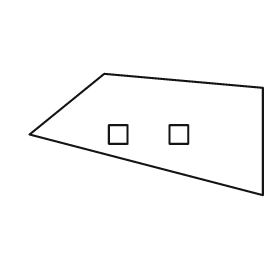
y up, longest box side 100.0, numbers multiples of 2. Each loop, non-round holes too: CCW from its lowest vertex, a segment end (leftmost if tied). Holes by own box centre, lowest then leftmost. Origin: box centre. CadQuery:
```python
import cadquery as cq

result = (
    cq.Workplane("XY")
    .moveTo(50.0, -26.0)
    .lineTo(50.0, 20.0)
    .lineTo(-18.0, 26.0)
    .lineTo(-50.0, 0.0)
    .close()
    .moveTo(-16.0, -4.0)
    .lineTo(-8.0, -4.0)
    .lineTo(-8.0, 4.0)
    .lineTo(-16.0, 4.0)
    .close()
    .moveTo(10.0, -4.0)
    .lineTo(18.0, -4.0)
    .lineTo(18.0, 4.0)
    .lineTo(10.0, 4.0)
    .close()
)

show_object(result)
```